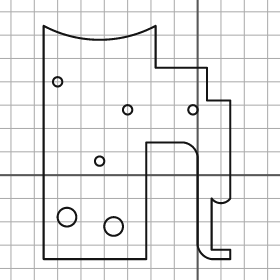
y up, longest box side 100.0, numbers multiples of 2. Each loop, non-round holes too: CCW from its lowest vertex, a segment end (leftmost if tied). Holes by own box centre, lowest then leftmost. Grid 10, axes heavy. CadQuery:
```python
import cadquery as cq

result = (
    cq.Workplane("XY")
    .moveTo(-66.0, -36.0)
    .lineTo(-22.0, -36.0)
    .lineTo(-22.0, 14.0)
    .lineTo(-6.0, 14.0)
    .threePointArc((-2.0, 12.0), (0.0, 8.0))
    .lineTo(0.0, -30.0)
    .threePointArc((2.0, -34.0), (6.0, -36.0))
    .lineTo(14.0, -36.0)
    .lineTo(14.0, -32.0)
    .lineTo(6.0, -32.0)
    .lineTo(6.0, -10.0)
    .threePointArc((10.0, -12.0), (14.0, -10.0))
    .lineTo(14.0, 32.0)
    .lineTo(4.0, 32.0)
    .lineTo(4.0, 46.0)
    .lineTo(-18.0, 46.0)
    .lineTo(-18.0, 64.0)
    .threePointArc((-42.0, 58.0), (-66.0, 64.0))
    .close()
    .moveTo(-36.0, -22.0)
    .circle(4.0)
    .moveTo(-56.0, -18.0)
    .circle(4.0)
    .moveTo(-42.0, 6.0)
    .circle(2.0)
    .moveTo(-30.0, 28.0)
    .circle(2.0)
    .moveTo(-2.0, 28.0)
    .circle(2.0)
    .moveTo(-60.0, 40.0)
    .circle(2.0)
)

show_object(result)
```